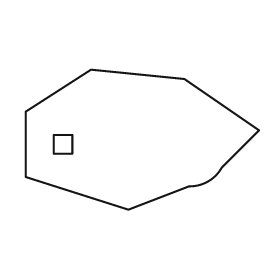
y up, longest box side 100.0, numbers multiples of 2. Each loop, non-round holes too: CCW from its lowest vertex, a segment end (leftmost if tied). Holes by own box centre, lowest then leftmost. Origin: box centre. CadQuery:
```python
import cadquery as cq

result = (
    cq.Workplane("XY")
    .moveTo(-6.0, -30.0)
    .lineTo(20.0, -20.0)
    .threePointArc((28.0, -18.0), (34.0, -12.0))
    .lineTo(50.0, 4.0)
    .lineTo(18.0, 26.0)
    .lineTo(-22.0, 30.0)
    .lineTo(-50.0, 12.0)
    .lineTo(-50.0, -16.0)
    .close()
    .moveTo(-38.0, -6.0)
    .lineTo(-30.0, -6.0)
    .lineTo(-30.0, 2.0)
    .lineTo(-38.0, 2.0)
    .close()
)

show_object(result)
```